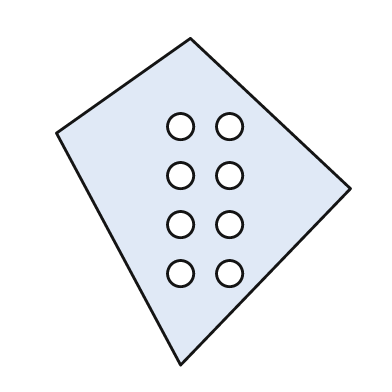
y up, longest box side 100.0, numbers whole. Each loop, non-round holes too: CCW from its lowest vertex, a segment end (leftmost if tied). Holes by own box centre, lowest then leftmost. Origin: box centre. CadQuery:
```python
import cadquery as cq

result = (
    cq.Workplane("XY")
    .moveTo(-7.0, -50.0)
    .lineTo(45.0, 4.0)
    .lineTo(-4.0, 50.0)
    .lineTo(-45.0, 21.0)
    .close()
    .moveTo(-7.0, -22.0)
    .circle(4.0)
    .moveTo(8.0, -22.0)
    .circle(4.0)
    .moveTo(-7.0, -7.0)
    .circle(4.0)
    .moveTo(8.0, -7.0)
    .circle(4.0)
    .moveTo(-7.0, 8.0)
    .circle(4.0)
    .moveTo(8.0, 8.0)
    .circle(4.0)
    .moveTo(-7.0, 23.0)
    .circle(4.0)
    .moveTo(8.0, 23.0)
    .circle(4.0)
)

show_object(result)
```